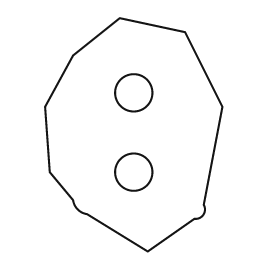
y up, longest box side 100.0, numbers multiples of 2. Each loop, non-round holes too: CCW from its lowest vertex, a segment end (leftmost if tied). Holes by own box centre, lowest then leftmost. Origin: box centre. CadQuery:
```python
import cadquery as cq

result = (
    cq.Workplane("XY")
    .moveTo(6.0, -50.0)
    .lineTo(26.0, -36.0)
    .threePointArc((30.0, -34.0), (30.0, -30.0))
    .lineTo(38.0, 12.0)
    .lineTo(22.0, 44.0)
    .lineTo(-6.0, 50.0)
    .lineTo(-26.0, 34.0)
    .lineTo(-38.0, 12.0)
    .lineTo(-36.0, -16.0)
    .lineTo(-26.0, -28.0)
    .threePointArc((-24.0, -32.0), (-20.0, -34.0))
    .close()
    .moveTo(0.0, -16.0)
    .circle(8.0)
    .moveTo(0.0, 18.0)
    .circle(8.0)
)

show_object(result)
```